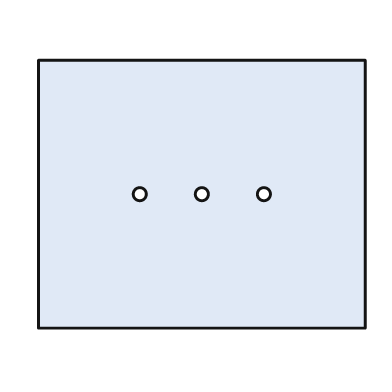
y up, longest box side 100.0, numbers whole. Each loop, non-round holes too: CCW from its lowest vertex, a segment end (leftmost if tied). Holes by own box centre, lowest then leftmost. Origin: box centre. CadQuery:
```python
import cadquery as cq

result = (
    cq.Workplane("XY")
    .moveTo(-50.0, -41.0)
    .lineTo(50.0, -41.0)
    .lineTo(50.0, 41.0)
    .lineTo(-50.0, 41.0)
    .close()
    .moveTo(-19.0, 0.0)
    .circle(2.0)
    .moveTo(0.0, 0.0)
    .circle(2.0)
    .moveTo(19.0, 0.0)
    .circle(2.0)
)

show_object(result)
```